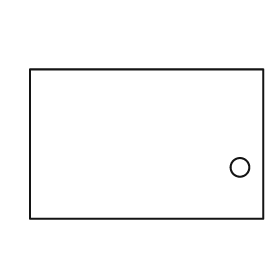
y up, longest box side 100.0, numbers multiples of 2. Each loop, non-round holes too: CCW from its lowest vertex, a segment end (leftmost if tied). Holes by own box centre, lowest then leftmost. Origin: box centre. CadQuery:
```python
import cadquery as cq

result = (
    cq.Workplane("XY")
    .moveTo(-50.0, -32.0)
    .lineTo(50.0, -32.0)
    .lineTo(50.0, 32.0)
    .lineTo(-50.0, 32.0)
    .close()
    .moveTo(40.0, -10.0)
    .circle(4.0)
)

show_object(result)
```